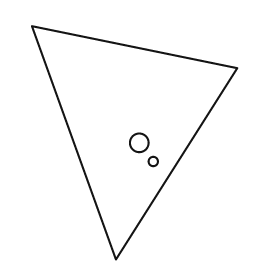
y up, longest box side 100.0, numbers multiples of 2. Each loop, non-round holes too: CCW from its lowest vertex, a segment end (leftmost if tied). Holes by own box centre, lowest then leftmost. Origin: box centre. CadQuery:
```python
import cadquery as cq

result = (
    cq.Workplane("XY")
    .moveTo(-8.0, -50.0)
    .lineTo(44.0, 32.0)
    .lineTo(-44.0, 50.0)
    .close()
    .moveTo(8.0, -8.0)
    .circle(2.0)
    .moveTo(2.0, 0.0)
    .circle(4.0)
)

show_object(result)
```